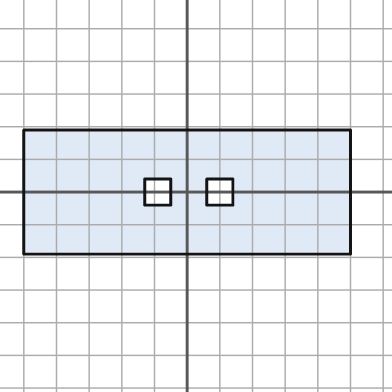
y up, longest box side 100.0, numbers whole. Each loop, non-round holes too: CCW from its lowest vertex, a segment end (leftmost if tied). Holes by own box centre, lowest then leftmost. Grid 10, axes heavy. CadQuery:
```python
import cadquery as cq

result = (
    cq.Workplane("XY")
    .moveTo(-50.0, -19.0)
    .lineTo(50.0, -19.0)
    .lineTo(50.0, 19.0)
    .lineTo(-50.0, 19.0)
    .close()
    .moveTo(-13.0, -4.0)
    .lineTo(-5.0, -4.0)
    .lineTo(-5.0, 4.0)
    .lineTo(-13.0, 4.0)
    .close()
    .moveTo(6.0, -4.0)
    .lineTo(14.0, -4.0)
    .lineTo(14.0, 4.0)
    .lineTo(6.0, 4.0)
    .close()
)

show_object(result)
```